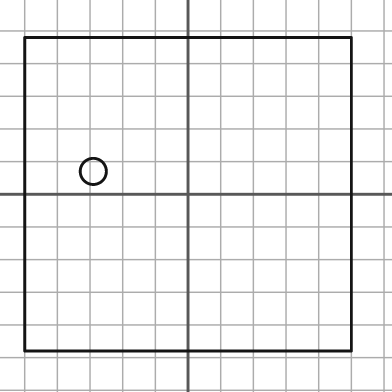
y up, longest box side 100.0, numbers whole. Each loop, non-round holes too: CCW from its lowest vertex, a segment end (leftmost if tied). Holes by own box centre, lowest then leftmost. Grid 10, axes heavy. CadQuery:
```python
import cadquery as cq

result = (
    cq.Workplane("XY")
    .moveTo(-50.0, -48.0)
    .lineTo(50.0, -48.0)
    .lineTo(50.0, 48.0)
    .lineTo(-50.0, 48.0)
    .close()
    .moveTo(-29.0, 7.0)
    .circle(4.0)
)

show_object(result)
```